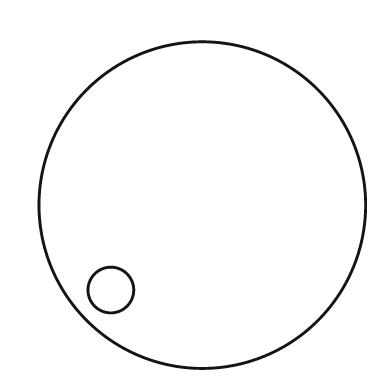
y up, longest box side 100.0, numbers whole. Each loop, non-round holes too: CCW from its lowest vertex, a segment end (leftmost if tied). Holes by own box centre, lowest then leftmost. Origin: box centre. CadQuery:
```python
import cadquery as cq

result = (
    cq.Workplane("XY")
    .moveTo(0.0, 0.0)
    .circle(50.0)
    .moveTo(-28.0, -26.0)
    .circle(7.0)
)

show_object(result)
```